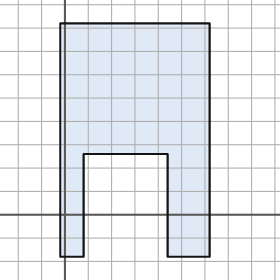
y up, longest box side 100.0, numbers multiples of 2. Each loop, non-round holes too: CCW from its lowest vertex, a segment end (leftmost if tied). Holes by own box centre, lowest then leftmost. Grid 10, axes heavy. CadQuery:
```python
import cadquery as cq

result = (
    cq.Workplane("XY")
    .moveTo(-2.0, -18.0)
    .lineTo(8.0, -18.0)
    .lineTo(8.0, 26.0)
    .lineTo(44.0, 26.0)
    .lineTo(44.0, -18.0)
    .lineTo(62.0, -18.0)
    .lineTo(62.0, 82.0)
    .lineTo(-2.0, 82.0)
    .close()
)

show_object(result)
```